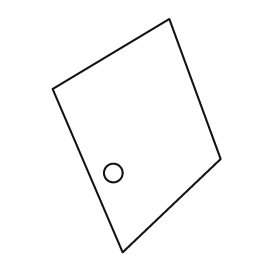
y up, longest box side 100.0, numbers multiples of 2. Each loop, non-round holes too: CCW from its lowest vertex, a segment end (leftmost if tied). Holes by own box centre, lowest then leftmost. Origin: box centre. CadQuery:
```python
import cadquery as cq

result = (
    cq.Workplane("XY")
    .moveTo(-6.0, -50.0)
    .lineTo(36.0, -10.0)
    .lineTo(14.0, 50.0)
    .lineTo(-36.0, 20.0)
    .close()
    .moveTo(-10.0, -16.0)
    .circle(4.0)
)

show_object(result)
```